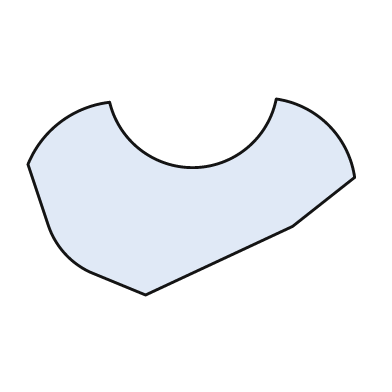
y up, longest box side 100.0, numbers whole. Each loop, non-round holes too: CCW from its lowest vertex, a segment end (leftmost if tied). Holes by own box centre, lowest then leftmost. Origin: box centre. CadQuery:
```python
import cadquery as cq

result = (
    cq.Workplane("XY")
    .moveTo(-14.0, -30.0)
    .lineTo(31.0, -9.0)
    .lineTo(50.0, 6.0)
    .threePointArc((42.0, 22.0), (26.0, 30.0))
    .threePointArc((1.0, 9.0), (-25.0, 29.0))
    .threePointArc((-40.0, 23.0), (-50.0, 10.0))
    .lineTo(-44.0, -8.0)
    .threePointArc((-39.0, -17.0), (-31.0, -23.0))
    .close()
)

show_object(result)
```